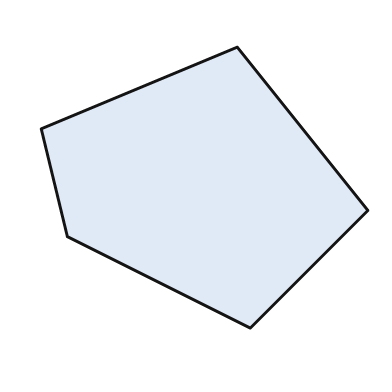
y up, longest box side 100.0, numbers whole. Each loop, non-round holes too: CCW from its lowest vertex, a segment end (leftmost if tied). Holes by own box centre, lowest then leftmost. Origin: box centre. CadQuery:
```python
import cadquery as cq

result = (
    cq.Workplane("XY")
    .moveTo(14.0, -43.0)
    .lineTo(50.0, -7.0)
    .lineTo(10.0, 43.0)
    .lineTo(-50.0, 18.0)
    .lineTo(-42.0, -15.0)
    .close()
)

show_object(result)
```